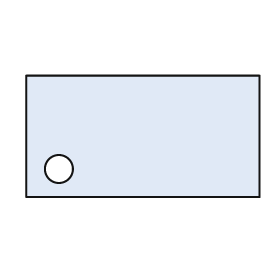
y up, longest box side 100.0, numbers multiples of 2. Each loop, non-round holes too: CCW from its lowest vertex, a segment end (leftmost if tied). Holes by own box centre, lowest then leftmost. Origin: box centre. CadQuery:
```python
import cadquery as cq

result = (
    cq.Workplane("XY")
    .moveTo(-50.0, -26.0)
    .lineTo(50.0, -26.0)
    .lineTo(50.0, 26.0)
    .lineTo(-50.0, 26.0)
    .close()
    .moveTo(-36.0, -14.0)
    .circle(6.0)
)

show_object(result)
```